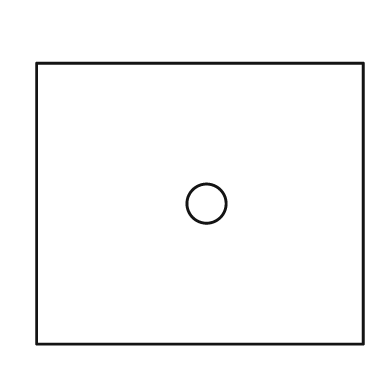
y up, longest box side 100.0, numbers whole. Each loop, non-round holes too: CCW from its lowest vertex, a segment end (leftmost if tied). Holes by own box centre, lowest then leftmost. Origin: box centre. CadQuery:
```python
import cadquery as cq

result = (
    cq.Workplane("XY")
    .moveTo(-50.0, -43.0)
    .lineTo(50.0, -43.0)
    .lineTo(50.0, 43.0)
    .lineTo(-50.0, 43.0)
    .close()
    .moveTo(2.0, 0.0)
    .circle(6.0)
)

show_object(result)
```